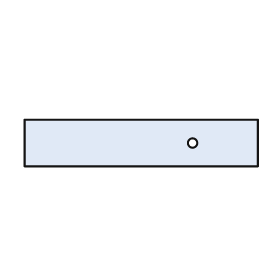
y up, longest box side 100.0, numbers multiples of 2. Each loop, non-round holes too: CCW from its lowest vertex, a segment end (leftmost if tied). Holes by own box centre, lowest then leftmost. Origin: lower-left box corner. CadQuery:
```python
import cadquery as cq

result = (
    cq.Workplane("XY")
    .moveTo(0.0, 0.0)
    .lineTo(100.0, 0.0)
    .lineTo(100.0, 20.0)
    .lineTo(0.0, 20.0)
    .close()
    .moveTo(72.0, 10.0)
    .circle(2.0)
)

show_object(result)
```